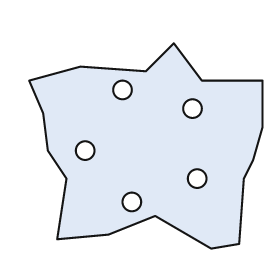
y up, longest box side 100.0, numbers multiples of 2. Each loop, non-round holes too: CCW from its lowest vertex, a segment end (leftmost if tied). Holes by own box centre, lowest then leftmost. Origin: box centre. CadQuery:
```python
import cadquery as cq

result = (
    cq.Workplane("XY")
    .moveTo(28.0, -44.0)
    .lineTo(40.0, -42.0)
    .lineTo(42.0, -14.0)
    .lineTo(46.0, -6.0)
    .lineTo(50.0, 8.0)
    .lineTo(50.0, 28.0)
    .lineTo(24.0, 28.0)
    .lineTo(12.0, 44.0)
    .lineTo(0.0, 32.0)
    .lineTo(-28.0, 34.0)
    .lineTo(-50.0, 28.0)
    .lineTo(-44.0, 14.0)
    .lineTo(-42.0, -2.0)
    .lineTo(-34.0, -14.0)
    .lineTo(-38.0, -40.0)
    .lineTo(-16.0, -38.0)
    .lineTo(4.0, -30.0)
    .close()
    .moveTo(-6.0, -24.0)
    .circle(4.0)
    .moveTo(22.0, -14.0)
    .circle(4.0)
    .moveTo(-26.0, -2.0)
    .circle(4.0)
    .moveTo(20.0, 16.0)
    .circle(4.0)
    .moveTo(-10.0, 24.0)
    .circle(4.0)
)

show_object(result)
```